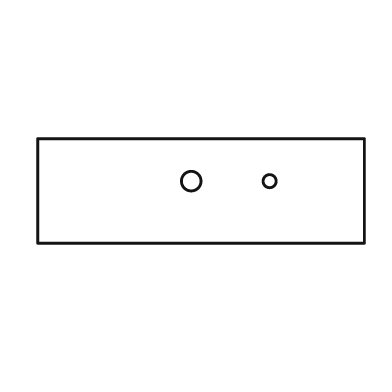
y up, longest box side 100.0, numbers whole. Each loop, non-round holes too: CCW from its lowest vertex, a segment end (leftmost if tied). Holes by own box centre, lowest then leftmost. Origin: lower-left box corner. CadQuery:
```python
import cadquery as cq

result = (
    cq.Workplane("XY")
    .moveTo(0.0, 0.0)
    .lineTo(100.0, 0.0)
    .lineTo(100.0, 32.0)
    .lineTo(0.0, 32.0)
    .close()
    .moveTo(47.0, 19.0)
    .circle(3.0)
    .moveTo(71.0, 19.0)
    .circle(2.0)
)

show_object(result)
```